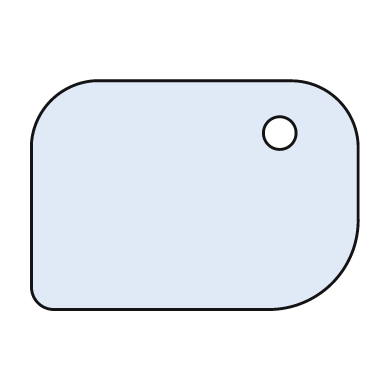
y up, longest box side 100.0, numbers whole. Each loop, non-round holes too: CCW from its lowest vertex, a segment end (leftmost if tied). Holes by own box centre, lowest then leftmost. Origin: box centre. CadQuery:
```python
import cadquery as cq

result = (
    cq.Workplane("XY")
    .moveTo(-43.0, -35.0)
    .lineTo(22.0, -35.0)
    .threePointArc((42.0, -27.0), (50.0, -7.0))
    .lineTo(50.0, 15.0)
    .threePointArc((44.0, 29.0), (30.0, 35.0))
    .lineTo(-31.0, 35.0)
    .threePointArc((-44.0, 29.0), (-50.0, 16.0))
    .lineTo(-50.0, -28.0)
    .threePointArc((-48.0, -33.0), (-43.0, -35.0))
    .close()
    .moveTo(26.0, 19.0)
    .circle(5.0)
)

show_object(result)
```